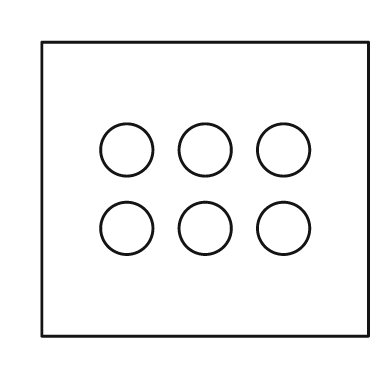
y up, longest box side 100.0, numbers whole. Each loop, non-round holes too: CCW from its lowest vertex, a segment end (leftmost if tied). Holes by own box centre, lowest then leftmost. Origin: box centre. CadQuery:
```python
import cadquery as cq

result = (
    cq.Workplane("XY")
    .moveTo(-50.0, -45.0)
    .lineTo(50.0, -45.0)
    .lineTo(50.0, 45.0)
    .lineTo(-50.0, 45.0)
    .close()
    .moveTo(-24.0, -12.0)
    .circle(8.0)
    .moveTo(0.0, -12.0)
    .circle(8.0)
    .moveTo(24.0, -12.0)
    .circle(8.0)
    .moveTo(-24.0, 12.0)
    .circle(8.0)
    .moveTo(0.0, 12.0)
    .circle(8.0)
    .moveTo(24.0, 12.0)
    .circle(8.0)
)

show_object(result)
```